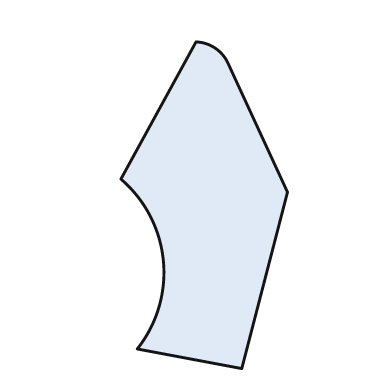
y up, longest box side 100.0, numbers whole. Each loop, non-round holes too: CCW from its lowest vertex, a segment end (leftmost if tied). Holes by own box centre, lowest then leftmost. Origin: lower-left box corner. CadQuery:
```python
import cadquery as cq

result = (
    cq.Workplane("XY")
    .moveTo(37.0, 0.0)
    .lineTo(51.0, 54.0)
    .lineTo(33.0, 93.0)
    .threePointArc((29.0, 98.0), (23.0, 100.0))
    .lineTo(0.0, 58.0)
    .threePointArc((13.0, 33.0), (5.0, 6.0))
    .close()
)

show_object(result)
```